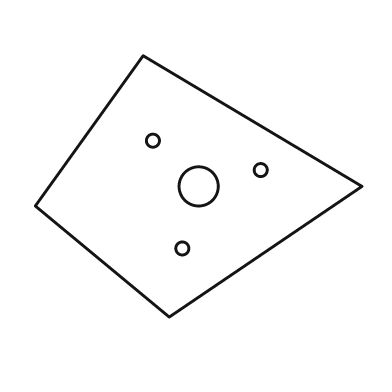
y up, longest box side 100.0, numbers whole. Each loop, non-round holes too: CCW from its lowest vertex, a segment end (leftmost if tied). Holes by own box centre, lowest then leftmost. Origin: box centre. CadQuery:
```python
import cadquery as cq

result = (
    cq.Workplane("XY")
    .moveTo(-9.0, -40.0)
    .lineTo(50.0, 0.0)
    .lineTo(-17.0, 40.0)
    .lineTo(-50.0, -6.0)
    .close()
    .moveTo(-5.0, -19.0)
    .circle(2.0)
    .moveTo(0.0, 0.0)
    .circle(6.0)
    .moveTo(19.0, 5.0)
    .circle(2.0)
    .moveTo(-14.0, 14.0)
    .circle(2.0)
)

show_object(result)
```